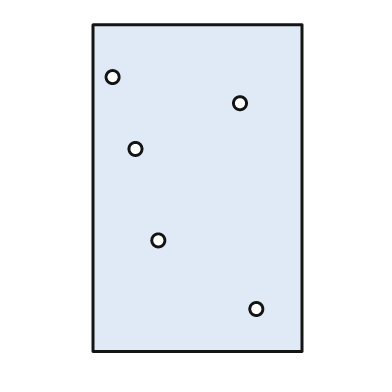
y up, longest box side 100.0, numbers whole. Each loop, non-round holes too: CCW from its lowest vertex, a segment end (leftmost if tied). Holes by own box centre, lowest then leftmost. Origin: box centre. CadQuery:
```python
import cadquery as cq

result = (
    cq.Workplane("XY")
    .moveTo(-32.0, -50.0)
    .lineTo(32.0, -50.0)
    .lineTo(32.0, 50.0)
    .lineTo(-32.0, 50.0)
    .close()
    .moveTo(18.0, -37.0)
    .circle(2.0)
    .moveTo(-12.0, -16.0)
    .circle(2.0)
    .moveTo(-19.0, 12.0)
    .circle(2.0)
    .moveTo(13.0, 26.0)
    .circle(2.0)
    .moveTo(-26.0, 34.0)
    .circle(2.0)
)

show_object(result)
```